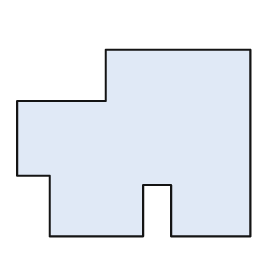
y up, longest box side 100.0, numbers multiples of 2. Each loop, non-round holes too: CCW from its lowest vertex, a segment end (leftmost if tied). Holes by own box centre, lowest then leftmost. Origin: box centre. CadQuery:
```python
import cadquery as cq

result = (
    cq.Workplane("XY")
    .moveTo(-36.0, -40.0)
    .lineTo(4.0, -40.0)
    .lineTo(4.0, -18.0)
    .lineTo(16.0, -18.0)
    .lineTo(16.0, -40.0)
    .lineTo(50.0, -40.0)
    .lineTo(50.0, 40.0)
    .lineTo(-12.0, 40.0)
    .lineTo(-12.0, 18.0)
    .lineTo(-50.0, 18.0)
    .lineTo(-50.0, -14.0)
    .lineTo(-36.0, -14.0)
    .close()
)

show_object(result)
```